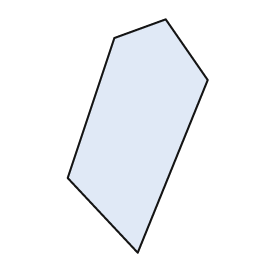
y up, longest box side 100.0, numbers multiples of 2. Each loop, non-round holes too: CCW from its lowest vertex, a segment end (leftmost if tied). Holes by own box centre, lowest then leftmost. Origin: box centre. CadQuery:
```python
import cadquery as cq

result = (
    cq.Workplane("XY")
    .moveTo(0.0, -50.0)
    .lineTo(30.0, 24.0)
    .lineTo(12.0, 50.0)
    .lineTo(-10.0, 42.0)
    .lineTo(-30.0, -18.0)
    .close()
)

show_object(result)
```